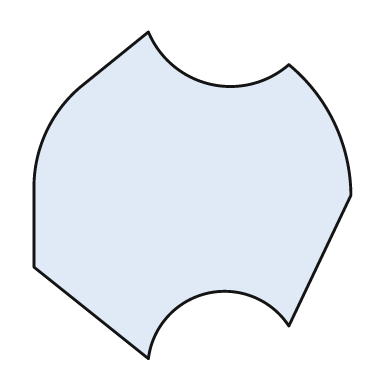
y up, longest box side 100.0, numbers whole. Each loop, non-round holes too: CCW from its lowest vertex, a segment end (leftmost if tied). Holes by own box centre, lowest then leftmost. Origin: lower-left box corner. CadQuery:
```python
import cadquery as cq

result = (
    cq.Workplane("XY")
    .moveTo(35.0, 0.0)
    .threePointArc((53.0, 20.0), (78.0, 10.0))
    .lineTo(97.0, 50.0)
    .threePointArc((92.0, 72.0), (78.0, 90.0))
    .threePointArc((54.0, 84.0), (35.0, 100.0))
    .lineTo(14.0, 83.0)
    .threePointArc((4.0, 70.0), (0.0, 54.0))
    .lineTo(0.0, 28.0)
    .close()
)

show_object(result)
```